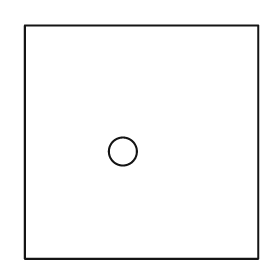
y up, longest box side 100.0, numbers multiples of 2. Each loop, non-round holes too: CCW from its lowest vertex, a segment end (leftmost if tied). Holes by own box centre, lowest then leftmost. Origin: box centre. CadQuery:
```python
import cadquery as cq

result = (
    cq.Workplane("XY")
    .moveTo(-50.0, -50.0)
    .lineTo(50.0, -50.0)
    .lineTo(50.0, 50.0)
    .lineTo(-50.0, 50.0)
    .close()
    .moveTo(-8.0, -4.0)
    .circle(6.0)
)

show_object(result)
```